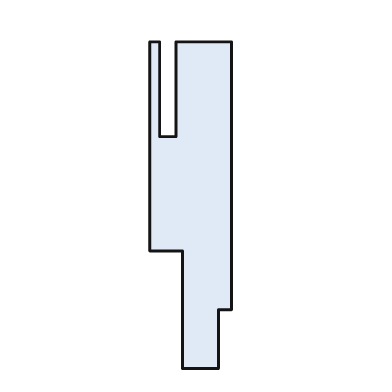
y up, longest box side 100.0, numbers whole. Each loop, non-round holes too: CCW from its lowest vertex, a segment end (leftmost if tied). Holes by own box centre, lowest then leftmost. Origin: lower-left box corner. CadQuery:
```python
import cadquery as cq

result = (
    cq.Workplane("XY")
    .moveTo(10.0, 0.0)
    .lineTo(21.0, 0.0)
    .lineTo(21.0, 18.0)
    .lineTo(25.0, 18.0)
    .lineTo(25.0, 100.0)
    .lineTo(8.0, 100.0)
    .lineTo(8.0, 71.0)
    .lineTo(3.0, 71.0)
    .lineTo(3.0, 100.0)
    .lineTo(0.0, 100.0)
    .lineTo(0.0, 36.0)
    .lineTo(10.0, 36.0)
    .close()
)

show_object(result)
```